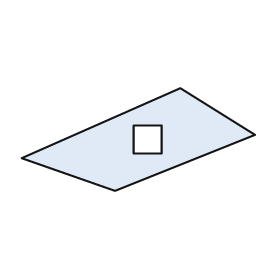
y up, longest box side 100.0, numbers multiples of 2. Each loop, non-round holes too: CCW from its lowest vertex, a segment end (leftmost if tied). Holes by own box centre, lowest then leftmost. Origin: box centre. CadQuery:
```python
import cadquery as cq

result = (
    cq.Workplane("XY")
    .moveTo(-10.0, -22.0)
    .lineTo(50.0, 2.0)
    .lineTo(18.0, 22.0)
    .lineTo(-50.0, -8.0)
    .close()
    .moveTo(-2.0, -6.0)
    .lineTo(10.0, -6.0)
    .lineTo(10.0, 6.0)
    .lineTo(-2.0, 6.0)
    .close()
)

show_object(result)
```